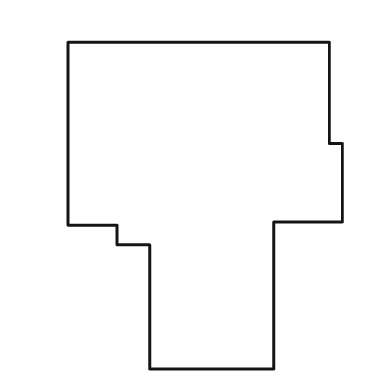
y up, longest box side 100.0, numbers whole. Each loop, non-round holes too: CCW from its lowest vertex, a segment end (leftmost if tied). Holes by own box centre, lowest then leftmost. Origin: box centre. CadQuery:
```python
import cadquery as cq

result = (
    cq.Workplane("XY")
    .moveTo(-17.0, -50.0)
    .lineTo(21.0, -50.0)
    .lineTo(21.0, -5.0)
    .lineTo(42.0, -5.0)
    .lineTo(42.0, 19.0)
    .lineTo(38.0, 19.0)
    .lineTo(38.0, 50.0)
    .lineTo(-42.0, 50.0)
    .lineTo(-42.0, -6.0)
    .lineTo(-27.0, -6.0)
    .lineTo(-27.0, -12.0)
    .lineTo(-17.0, -12.0)
    .close()
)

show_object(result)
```